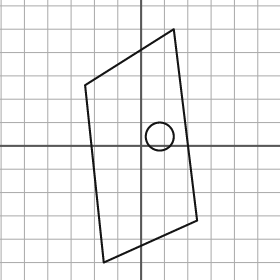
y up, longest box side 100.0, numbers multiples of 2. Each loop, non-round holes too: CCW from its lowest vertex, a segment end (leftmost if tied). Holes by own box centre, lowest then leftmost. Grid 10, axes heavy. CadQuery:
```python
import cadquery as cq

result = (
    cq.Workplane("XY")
    .moveTo(-16.0, -50.0)
    .lineTo(24.0, -32.0)
    .lineTo(14.0, 50.0)
    .lineTo(-24.0, 26.0)
    .close()
    .moveTo(8.0, 4.0)
    .circle(6.0)
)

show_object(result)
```